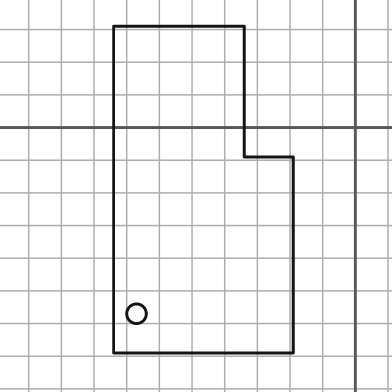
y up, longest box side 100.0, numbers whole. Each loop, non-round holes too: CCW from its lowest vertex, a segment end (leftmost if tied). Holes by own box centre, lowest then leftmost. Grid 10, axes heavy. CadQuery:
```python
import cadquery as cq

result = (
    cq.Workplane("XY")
    .moveTo(-74.0, -69.0)
    .lineTo(-19.0, -69.0)
    .lineTo(-19.0, -9.0)
    .lineTo(-34.0, -9.0)
    .lineTo(-34.0, 31.0)
    .lineTo(-74.0, 31.0)
    .close()
    .moveTo(-67.0, -57.0)
    .circle(3.0)
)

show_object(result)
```